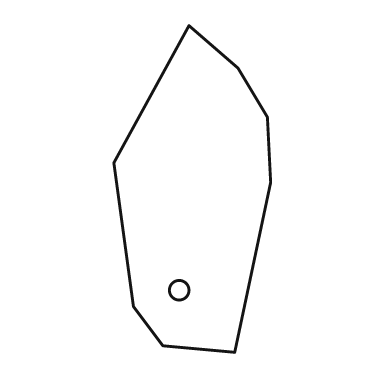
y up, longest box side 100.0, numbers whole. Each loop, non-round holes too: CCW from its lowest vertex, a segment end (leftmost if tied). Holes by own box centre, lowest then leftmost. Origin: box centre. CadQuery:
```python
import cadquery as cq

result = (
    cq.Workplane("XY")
    .moveTo(13.0, -50.0)
    .lineTo(24.0, 2.0)
    .lineTo(23.0, 22.0)
    .lineTo(14.0, 37.0)
    .lineTo(-1.0, 50.0)
    .lineTo(-24.0, 8.0)
    .lineTo(-18.0, -36.0)
    .lineTo(-9.0, -48.0)
    .close()
    .moveTo(-4.0, -31.0)
    .circle(3.0)
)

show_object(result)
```